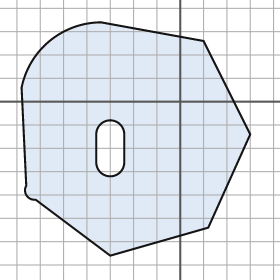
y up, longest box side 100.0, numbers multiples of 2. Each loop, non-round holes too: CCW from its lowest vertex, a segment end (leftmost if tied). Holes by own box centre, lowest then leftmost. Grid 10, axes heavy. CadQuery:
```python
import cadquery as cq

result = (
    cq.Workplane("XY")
    .moveTo(-30.0, -66.0)
    .lineTo(12.0, -54.0)
    .lineTo(30.0, -14.0)
    .lineTo(10.0, 26.0)
    .lineTo(-34.0, 34.0)
    .threePointArc((-56.0, 26.0), (-68.0, 6.0))
    .lineTo(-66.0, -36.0)
    .threePointArc((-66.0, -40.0), (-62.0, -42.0))
    .close()
    .moveTo(-36.0, -26.0)
    .threePointArc((-30.0, -32.0), (-24.0, -26.0))
    .lineTo(-24.0, -14.0)
    .threePointArc((-30.0, -8.0), (-36.0, -14.0))
    .close()
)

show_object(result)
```